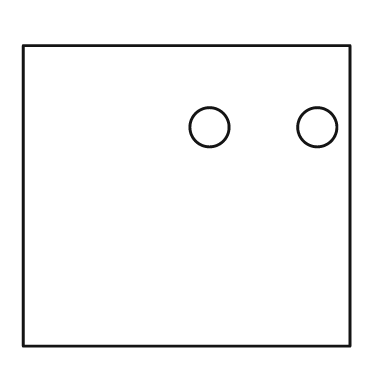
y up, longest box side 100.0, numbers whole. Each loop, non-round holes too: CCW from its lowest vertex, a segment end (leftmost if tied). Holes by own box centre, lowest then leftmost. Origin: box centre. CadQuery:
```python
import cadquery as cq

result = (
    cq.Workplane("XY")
    .moveTo(-50.0, -46.0)
    .lineTo(50.0, -46.0)
    .lineTo(50.0, 46.0)
    .lineTo(-50.0, 46.0)
    .close()
    .moveTo(7.0, 21.0)
    .circle(6.0)
    .moveTo(40.0, 21.0)
    .circle(6.0)
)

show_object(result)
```